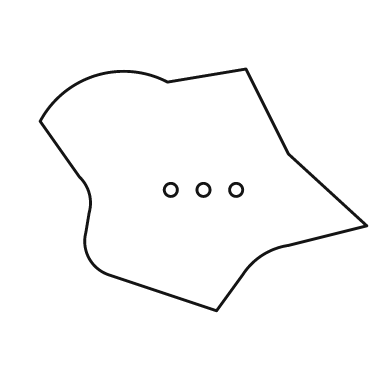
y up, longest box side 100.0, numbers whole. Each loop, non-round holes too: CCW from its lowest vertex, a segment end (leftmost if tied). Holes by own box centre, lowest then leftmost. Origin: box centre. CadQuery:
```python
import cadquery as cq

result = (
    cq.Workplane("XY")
    .moveTo(4.0, -37.0)
    .lineTo(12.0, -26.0)
    .threePointArc((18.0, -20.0), (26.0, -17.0))
    .lineTo(50.0, -11.0)
    .lineTo(26.0, 11.0)
    .lineTo(13.0, 37.0)
    .lineTo(-11.0, 33.0)
    .threePointArc((-33.0, 35.0), (-50.0, 21.0))
    .lineTo(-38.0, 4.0)
    .threePointArc((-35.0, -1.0), (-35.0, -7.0))
    .lineTo(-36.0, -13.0)
    .threePointArc((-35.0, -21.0), (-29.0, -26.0))
    .close()
    .moveTo(-10.0, 0.0)
    .circle(2.0)
    .moveTo(0.0, 0.0)
    .circle(2.0)
    .moveTo(10.0, 0.0)
    .circle(2.0)
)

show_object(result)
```